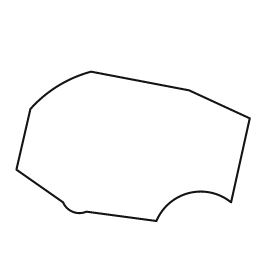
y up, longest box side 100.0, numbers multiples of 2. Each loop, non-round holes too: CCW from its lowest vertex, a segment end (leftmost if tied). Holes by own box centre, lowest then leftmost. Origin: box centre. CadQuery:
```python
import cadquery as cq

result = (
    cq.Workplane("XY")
    .moveTo(10.0, -32.0)
    .threePointArc((24.0, -20.0), (42.0, -24.0))
    .lineTo(50.0, 12.0)
    .lineTo(24.0, 24.0)
    .lineTo(-18.0, 32.0)
    .threePointArc((-32.0, 26.0), (-44.0, 16.0))
    .lineTo(-50.0, -10.0)
    .lineTo(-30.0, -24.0)
    .threePointArc((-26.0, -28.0), (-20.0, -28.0))
    .close()
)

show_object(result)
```